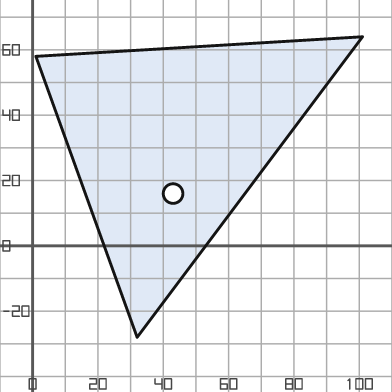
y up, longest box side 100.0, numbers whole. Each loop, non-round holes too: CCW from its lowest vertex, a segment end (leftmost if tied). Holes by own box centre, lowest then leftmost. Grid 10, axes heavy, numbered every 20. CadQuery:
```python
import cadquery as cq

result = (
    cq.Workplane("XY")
    .moveTo(32.0, -28.0)
    .lineTo(101.0, 64.0)
    .lineTo(1.0, 58.0)
    .close()
    .moveTo(43.0, 16.0)
    .circle(3.0)
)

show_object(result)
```